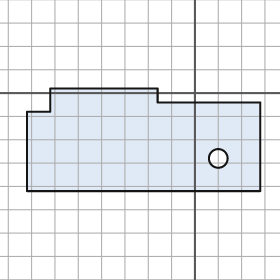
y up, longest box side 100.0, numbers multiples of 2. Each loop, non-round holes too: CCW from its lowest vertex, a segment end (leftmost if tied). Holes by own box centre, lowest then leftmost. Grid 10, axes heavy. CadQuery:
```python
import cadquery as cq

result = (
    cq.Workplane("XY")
    .moveTo(-72.0, -42.0)
    .lineTo(28.0, -42.0)
    .lineTo(28.0, -4.0)
    .lineTo(-16.0, -4.0)
    .lineTo(-16.0, 2.0)
    .lineTo(-62.0, 2.0)
    .lineTo(-62.0, -8.0)
    .lineTo(-72.0, -8.0)
    .close()
    .moveTo(10.0, -28.0)
    .circle(4.0)
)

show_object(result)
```